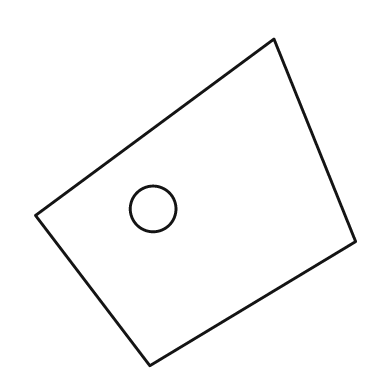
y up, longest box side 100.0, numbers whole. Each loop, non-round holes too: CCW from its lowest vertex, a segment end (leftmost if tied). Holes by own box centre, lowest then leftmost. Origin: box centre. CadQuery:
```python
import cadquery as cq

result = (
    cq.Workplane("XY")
    .moveTo(-14.0, -50.0)
    .lineTo(49.0, -12.0)
    .lineTo(24.0, 50.0)
    .lineTo(-49.0, -4.0)
    .close()
    .moveTo(-13.0, -2.0)
    .circle(7.0)
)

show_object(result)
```